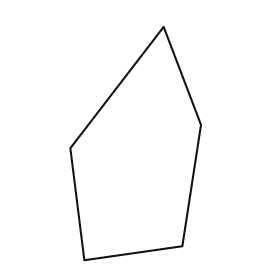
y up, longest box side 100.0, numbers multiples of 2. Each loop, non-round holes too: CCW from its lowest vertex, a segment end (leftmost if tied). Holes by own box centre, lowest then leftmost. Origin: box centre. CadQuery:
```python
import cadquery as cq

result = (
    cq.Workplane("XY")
    .moveTo(-22.0, -50.0)
    .lineTo(20.0, -44.0)
    .lineTo(28.0, 8.0)
    .lineTo(12.0, 50.0)
    .lineTo(-28.0, -2.0)
    .close()
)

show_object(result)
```